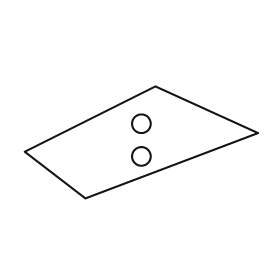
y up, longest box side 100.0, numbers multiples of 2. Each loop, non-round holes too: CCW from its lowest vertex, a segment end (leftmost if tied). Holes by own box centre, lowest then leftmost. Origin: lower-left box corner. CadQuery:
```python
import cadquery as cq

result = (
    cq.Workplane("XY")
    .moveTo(26.0, 0.0)
    .lineTo(100.0, 28.0)
    .lineTo(56.0, 48.0)
    .lineTo(0.0, 20.0)
    .close()
    .moveTo(50.0, 18.0)
    .circle(4.0)
    .moveTo(50.0, 32.0)
    .circle(4.0)
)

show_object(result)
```